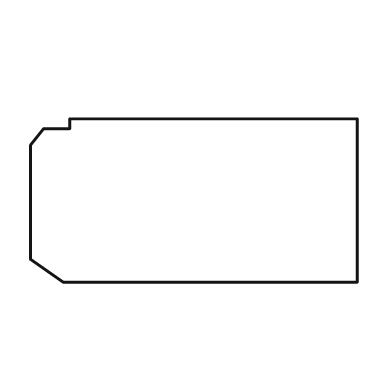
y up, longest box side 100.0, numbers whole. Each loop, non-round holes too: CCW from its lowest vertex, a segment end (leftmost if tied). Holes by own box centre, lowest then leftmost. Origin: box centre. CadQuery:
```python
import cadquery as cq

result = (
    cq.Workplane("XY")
    .moveTo(-40.0, -25.0)
    .lineTo(50.0, -25.0)
    .lineTo(50.0, 25.0)
    .lineTo(-38.0, 25.0)
    .lineTo(-38.0, 22.0)
    .lineTo(-46.0, 22.0)
    .lineTo(-50.0, 17.0)
    .lineTo(-50.0, -18.0)
    .close()
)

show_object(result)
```